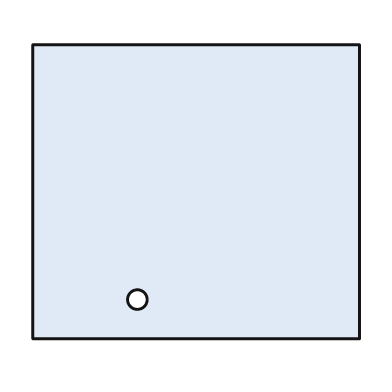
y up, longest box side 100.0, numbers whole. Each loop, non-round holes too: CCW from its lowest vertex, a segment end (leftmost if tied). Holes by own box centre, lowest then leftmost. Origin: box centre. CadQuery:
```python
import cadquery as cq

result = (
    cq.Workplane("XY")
    .moveTo(-50.0, -45.0)
    .lineTo(50.0, -45.0)
    .lineTo(50.0, 45.0)
    .lineTo(-50.0, 45.0)
    .close()
    .moveTo(-18.0, -33.0)
    .circle(3.0)
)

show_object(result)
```